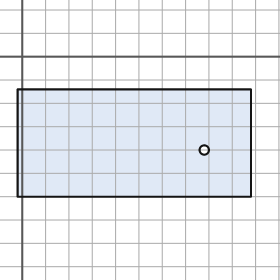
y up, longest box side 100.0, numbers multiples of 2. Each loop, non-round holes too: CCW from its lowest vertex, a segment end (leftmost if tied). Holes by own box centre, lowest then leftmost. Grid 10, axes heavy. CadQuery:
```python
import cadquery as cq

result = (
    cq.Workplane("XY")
    .moveTo(-2.0, -60.0)
    .lineTo(98.0, -60.0)
    .lineTo(98.0, -14.0)
    .lineTo(-2.0, -14.0)
    .close()
    .moveTo(78.0, -40.0)
    .circle(2.0)
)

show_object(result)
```